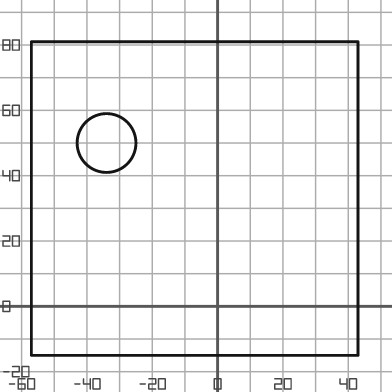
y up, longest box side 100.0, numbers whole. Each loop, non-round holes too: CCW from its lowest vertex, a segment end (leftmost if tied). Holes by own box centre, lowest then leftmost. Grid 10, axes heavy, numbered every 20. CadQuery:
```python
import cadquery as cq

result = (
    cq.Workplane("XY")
    .moveTo(-57.0, -15.0)
    .lineTo(43.0, -15.0)
    .lineTo(43.0, 81.0)
    .lineTo(-57.0, 81.0)
    .close()
    .moveTo(-34.0, 50.0)
    .circle(9.0)
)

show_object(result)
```